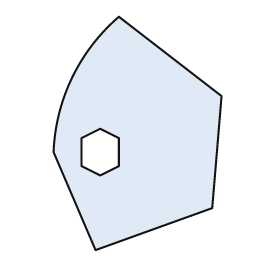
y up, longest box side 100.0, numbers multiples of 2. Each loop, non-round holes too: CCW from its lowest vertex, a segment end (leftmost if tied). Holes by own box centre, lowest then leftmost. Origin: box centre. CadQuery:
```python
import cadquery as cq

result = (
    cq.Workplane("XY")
    .moveTo(-18.0, -50.0)
    .lineTo(32.0, -32.0)
    .lineTo(36.0, 16.0)
    .lineTo(-8.0, 50.0)
    .threePointArc((-28.0, 24.0), (-36.0, -8.0))
    .close()
    .moveTo(-16.0, -18.0)
    .lineTo(-8.0, -14.0)
    .lineTo(-8.0, -2.0)
    .lineTo(-16.0, 2.0)
    .lineTo(-24.0, -2.0)
    .lineTo(-24.0, -14.0)
    .close()
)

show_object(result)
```